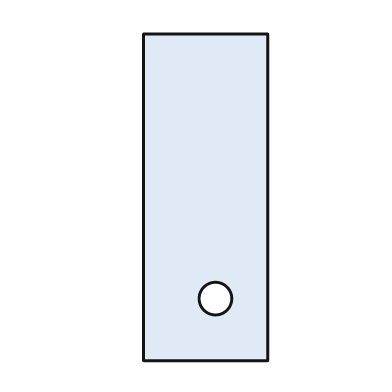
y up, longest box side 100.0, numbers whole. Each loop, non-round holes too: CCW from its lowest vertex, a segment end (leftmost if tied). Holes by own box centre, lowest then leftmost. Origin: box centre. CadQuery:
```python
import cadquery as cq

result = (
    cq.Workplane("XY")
    .moveTo(-19.0, -50.0)
    .lineTo(19.0, -50.0)
    .lineTo(19.0, 50.0)
    .lineTo(-19.0, 50.0)
    .close()
    .moveTo(3.0, -31.0)
    .circle(5.0)
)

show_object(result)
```